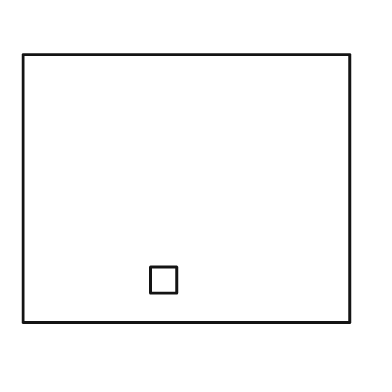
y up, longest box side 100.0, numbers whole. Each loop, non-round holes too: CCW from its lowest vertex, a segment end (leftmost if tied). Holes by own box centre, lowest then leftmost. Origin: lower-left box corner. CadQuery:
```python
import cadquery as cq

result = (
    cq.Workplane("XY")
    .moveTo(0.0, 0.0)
    .lineTo(100.0, 0.0)
    .lineTo(100.0, 82.0)
    .lineTo(0.0, 82.0)
    .close()
    .moveTo(39.0, 9.0)
    .lineTo(47.0, 9.0)
    .lineTo(47.0, 17.0)
    .lineTo(39.0, 17.0)
    .close()
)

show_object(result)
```